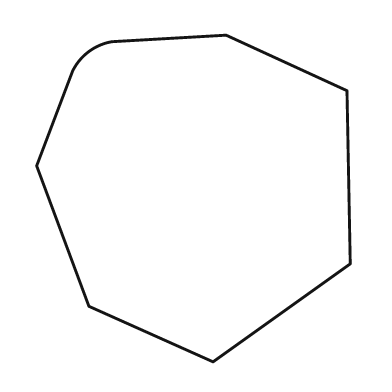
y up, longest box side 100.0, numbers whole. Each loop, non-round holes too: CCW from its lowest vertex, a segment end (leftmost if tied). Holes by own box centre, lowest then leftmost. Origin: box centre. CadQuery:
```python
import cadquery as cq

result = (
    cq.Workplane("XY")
    .moveTo(6.0, -50.0)
    .lineTo(48.0, -20.0)
    .lineTo(47.0, 33.0)
    .lineTo(10.0, 50.0)
    .lineTo(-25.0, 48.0)
    .threePointArc((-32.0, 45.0), (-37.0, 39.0))
    .lineTo(-48.0, 10.0)
    .lineTo(-32.0, -33.0)
    .close()
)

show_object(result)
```